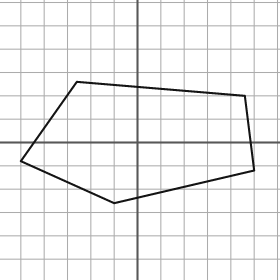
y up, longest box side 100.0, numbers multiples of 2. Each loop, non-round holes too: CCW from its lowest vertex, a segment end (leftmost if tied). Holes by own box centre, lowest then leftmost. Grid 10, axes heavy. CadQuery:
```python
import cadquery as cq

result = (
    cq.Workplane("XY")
    .moveTo(-10.0, -26.0)
    .lineTo(50.0, -12.0)
    .lineTo(46.0, 20.0)
    .lineTo(-26.0, 26.0)
    .lineTo(-50.0, -8.0)
    .close()
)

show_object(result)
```